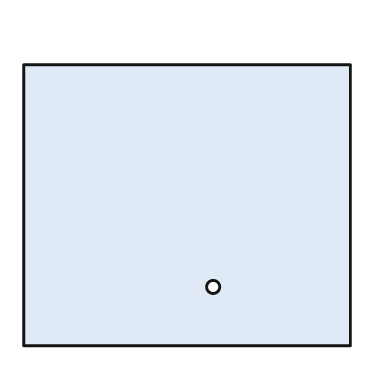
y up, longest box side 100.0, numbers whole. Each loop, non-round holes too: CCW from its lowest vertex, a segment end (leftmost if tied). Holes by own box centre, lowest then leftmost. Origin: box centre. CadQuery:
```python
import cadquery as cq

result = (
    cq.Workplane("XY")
    .moveTo(-50.0, -43.0)
    .lineTo(50.0, -43.0)
    .lineTo(50.0, 43.0)
    .lineTo(-50.0, 43.0)
    .close()
    .moveTo(8.0, -25.0)
    .circle(2.0)
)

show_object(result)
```